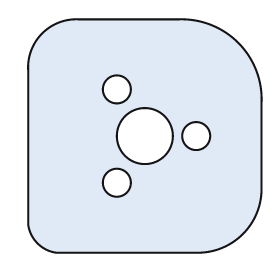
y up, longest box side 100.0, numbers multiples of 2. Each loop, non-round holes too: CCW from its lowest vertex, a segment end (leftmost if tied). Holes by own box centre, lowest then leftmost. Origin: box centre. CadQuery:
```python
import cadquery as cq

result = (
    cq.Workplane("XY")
    .moveTo(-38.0, -50.0)
    .lineTo(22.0, -50.0)
    .threePointArc((42.0, -42.0), (50.0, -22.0))
    .lineTo(50.0, 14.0)
    .threePointArc((40.0, 40.0), (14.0, 50.0))
    .lineTo(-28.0, 50.0)
    .threePointArc((-44.0, 44.0), (-50.0, 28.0))
    .lineTo(-50.0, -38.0)
    .threePointArc((-46.0, -46.0), (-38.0, -50.0))
    .close()
    .moveTo(-12.0, -20.0)
    .circle(6.0)
    .moveTo(0.0, 0.0)
    .circle(12.0)
    .moveTo(22.0, 0.0)
    .circle(6.0)
    .moveTo(-12.0, 20.0)
    .circle(6.0)
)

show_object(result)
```